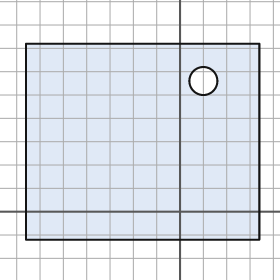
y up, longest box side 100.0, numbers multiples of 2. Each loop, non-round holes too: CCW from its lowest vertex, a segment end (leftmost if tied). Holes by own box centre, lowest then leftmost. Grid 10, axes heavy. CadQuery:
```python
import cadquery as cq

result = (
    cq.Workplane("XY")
    .moveTo(-66.0, -12.0)
    .lineTo(34.0, -12.0)
    .lineTo(34.0, 72.0)
    .lineTo(-66.0, 72.0)
    .close()
    .moveTo(10.0, 56.0)
    .circle(6.0)
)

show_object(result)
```